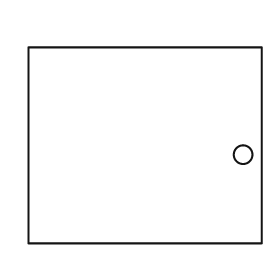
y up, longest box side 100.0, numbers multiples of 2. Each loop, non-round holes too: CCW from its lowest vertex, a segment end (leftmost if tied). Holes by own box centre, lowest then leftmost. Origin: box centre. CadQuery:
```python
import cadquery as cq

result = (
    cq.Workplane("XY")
    .moveTo(-50.0, -42.0)
    .lineTo(50.0, -42.0)
    .lineTo(50.0, 42.0)
    .lineTo(-50.0, 42.0)
    .close()
    .moveTo(42.0, -4.0)
    .circle(4.0)
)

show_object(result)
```